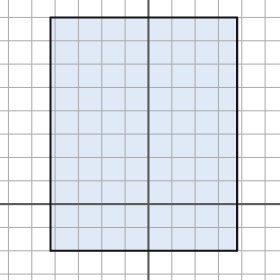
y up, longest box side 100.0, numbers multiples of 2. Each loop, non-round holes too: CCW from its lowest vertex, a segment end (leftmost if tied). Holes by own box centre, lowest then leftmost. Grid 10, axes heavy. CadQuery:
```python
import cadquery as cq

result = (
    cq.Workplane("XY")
    .moveTo(-42.0, -20.0)
    .lineTo(38.0, -20.0)
    .lineTo(38.0, 80.0)
    .lineTo(-42.0, 80.0)
    .close()
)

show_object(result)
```